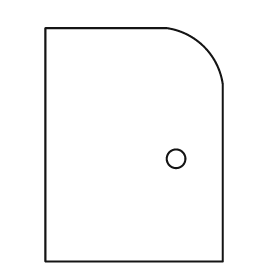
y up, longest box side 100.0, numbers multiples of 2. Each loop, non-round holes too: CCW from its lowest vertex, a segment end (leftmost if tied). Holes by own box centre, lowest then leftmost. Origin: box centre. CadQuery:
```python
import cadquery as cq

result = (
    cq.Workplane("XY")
    .moveTo(-38.0, -50.0)
    .lineTo(38.0, -50.0)
    .lineTo(38.0, 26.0)
    .threePointArc((30.0, 42.0), (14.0, 50.0))
    .lineTo(-38.0, 50.0)
    .close()
    .moveTo(18.0, -6.0)
    .circle(4.0)
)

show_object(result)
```